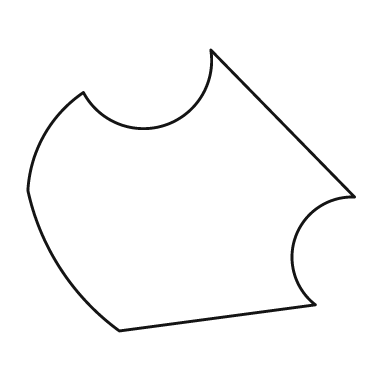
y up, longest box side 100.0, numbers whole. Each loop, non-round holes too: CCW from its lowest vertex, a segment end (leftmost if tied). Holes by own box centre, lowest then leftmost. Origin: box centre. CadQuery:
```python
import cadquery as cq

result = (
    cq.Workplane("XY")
    .moveTo(-22.0, -43.0)
    .lineTo(38.0, -35.0)
    .threePointArc((32.0, -14.0), (50.0, -2.0))
    .lineTo(6.0, 43.0)
    .threePointArc((-8.0, 20.0), (-33.0, 30.0))
    .threePointArc((-45.0, 17.0), (-50.0, 0.0))
    .threePointArc((-40.0, -24.0), (-22.0, -43.0))
    .close()
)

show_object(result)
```